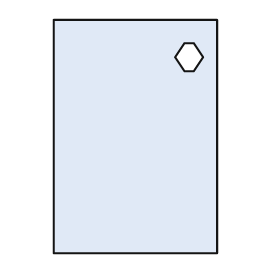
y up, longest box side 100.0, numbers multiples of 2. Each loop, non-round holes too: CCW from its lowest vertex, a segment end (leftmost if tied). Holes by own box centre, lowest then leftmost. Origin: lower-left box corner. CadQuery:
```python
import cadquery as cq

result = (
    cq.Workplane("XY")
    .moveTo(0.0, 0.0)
    .lineTo(70.0, 0.0)
    .lineTo(70.0, 100.0)
    .lineTo(0.0, 100.0)
    .close()
    .moveTo(56.0, 78.0)
    .lineTo(60.0, 78.0)
    .lineTo(64.0, 84.0)
    .lineTo(60.0, 90.0)
    .lineTo(56.0, 90.0)
    .lineTo(52.0, 84.0)
    .close()
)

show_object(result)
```